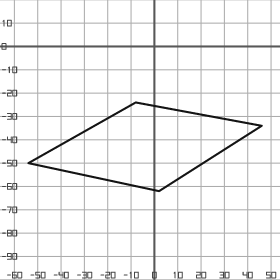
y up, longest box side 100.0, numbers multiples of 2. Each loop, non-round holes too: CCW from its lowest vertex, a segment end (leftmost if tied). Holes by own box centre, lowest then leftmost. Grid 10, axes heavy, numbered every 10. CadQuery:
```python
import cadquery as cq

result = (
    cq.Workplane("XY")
    .moveTo(2.0, -62.0)
    .lineTo(46.0, -34.0)
    .lineTo(-8.0, -24.0)
    .lineTo(-54.0, -50.0)
    .close()
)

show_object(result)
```